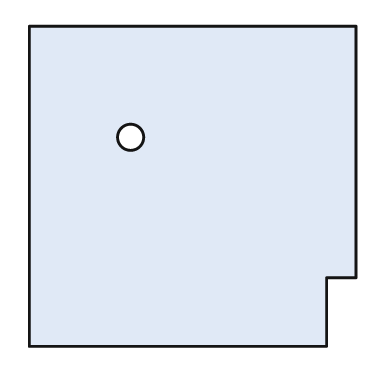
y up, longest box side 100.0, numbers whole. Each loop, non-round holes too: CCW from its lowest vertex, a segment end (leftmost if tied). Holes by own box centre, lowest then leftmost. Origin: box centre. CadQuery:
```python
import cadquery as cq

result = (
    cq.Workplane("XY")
    .moveTo(-50.0, -49.0)
    .lineTo(41.0, -49.0)
    .lineTo(41.0, -28.0)
    .lineTo(50.0, -28.0)
    .lineTo(50.0, 49.0)
    .lineTo(-50.0, 49.0)
    .close()
    .moveTo(-19.0, 15.0)
    .circle(4.0)
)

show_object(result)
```